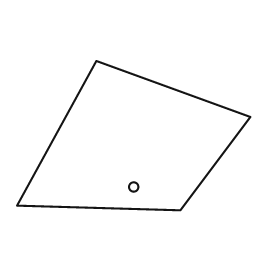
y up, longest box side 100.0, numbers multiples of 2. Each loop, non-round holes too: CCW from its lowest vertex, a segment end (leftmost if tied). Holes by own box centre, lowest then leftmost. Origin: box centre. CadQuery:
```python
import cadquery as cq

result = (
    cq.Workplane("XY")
    .moveTo(20.0, -32.0)
    .lineTo(50.0, 8.0)
    .lineTo(-16.0, 32.0)
    .lineTo(-50.0, -30.0)
    .close()
    .moveTo(0.0, -22.0)
    .circle(2.0)
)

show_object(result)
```